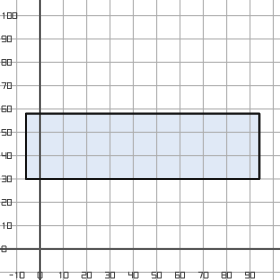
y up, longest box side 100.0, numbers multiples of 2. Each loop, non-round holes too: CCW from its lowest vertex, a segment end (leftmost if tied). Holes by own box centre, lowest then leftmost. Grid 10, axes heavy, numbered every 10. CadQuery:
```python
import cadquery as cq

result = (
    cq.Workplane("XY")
    .moveTo(-6.0, 30.0)
    .lineTo(94.0, 30.0)
    .lineTo(94.0, 58.0)
    .lineTo(-6.0, 58.0)
    .close()
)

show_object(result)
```